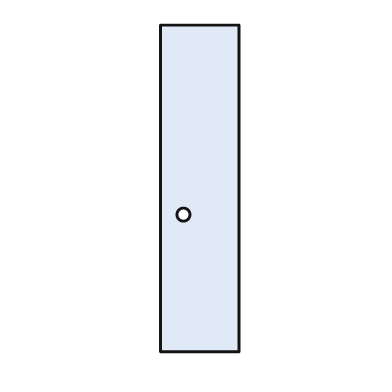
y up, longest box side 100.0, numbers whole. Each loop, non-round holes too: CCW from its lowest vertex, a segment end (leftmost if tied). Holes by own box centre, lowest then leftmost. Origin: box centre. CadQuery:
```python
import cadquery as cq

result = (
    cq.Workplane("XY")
    .moveTo(-12.0, -50.0)
    .lineTo(12.0, -50.0)
    .lineTo(12.0, 50.0)
    .lineTo(-12.0, 50.0)
    .close()
    .moveTo(-5.0, -8.0)
    .circle(2.0)
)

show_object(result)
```